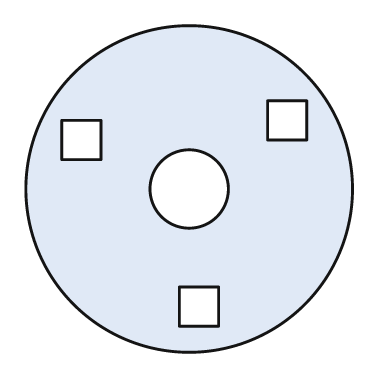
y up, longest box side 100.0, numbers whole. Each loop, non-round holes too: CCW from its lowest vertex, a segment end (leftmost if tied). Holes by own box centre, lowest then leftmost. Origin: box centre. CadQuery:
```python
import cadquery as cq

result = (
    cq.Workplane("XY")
    .moveTo(0.0, 0.0)
    .circle(50.0)
    .moveTo(-3.0, -42.0)
    .lineTo(9.0, -42.0)
    .lineTo(9.0, -30.0)
    .lineTo(-3.0, -30.0)
    .close()
    .moveTo(0.0, 0.0)
    .circle(12.0)
    .moveTo(-39.0, 9.0)
    .lineTo(-27.0, 9.0)
    .lineTo(-27.0, 21.0)
    .lineTo(-39.0, 21.0)
    .close()
    .moveTo(24.0, 15.0)
    .lineTo(36.0, 15.0)
    .lineTo(36.0, 27.0)
    .lineTo(24.0, 27.0)
    .close()
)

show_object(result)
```